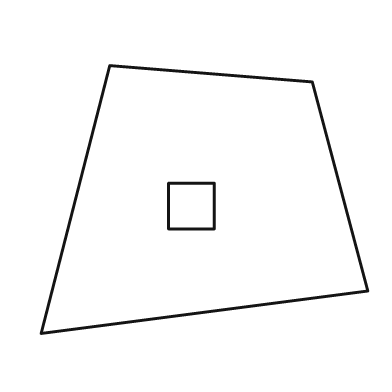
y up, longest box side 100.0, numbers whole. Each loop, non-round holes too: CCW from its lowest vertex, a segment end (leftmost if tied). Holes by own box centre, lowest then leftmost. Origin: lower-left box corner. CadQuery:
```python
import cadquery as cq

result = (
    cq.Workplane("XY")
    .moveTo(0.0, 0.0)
    .lineTo(100.0, 13.0)
    .lineTo(83.0, 77.0)
    .lineTo(21.0, 82.0)
    .close()
    .moveTo(39.0, 32.0)
    .lineTo(53.0, 32.0)
    .lineTo(53.0, 46.0)
    .lineTo(39.0, 46.0)
    .close()
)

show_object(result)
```